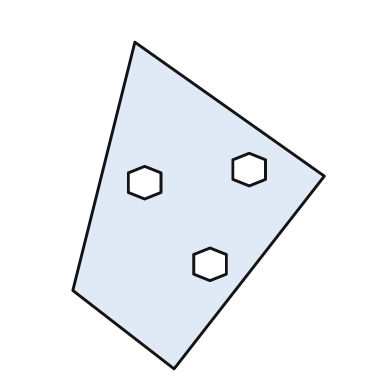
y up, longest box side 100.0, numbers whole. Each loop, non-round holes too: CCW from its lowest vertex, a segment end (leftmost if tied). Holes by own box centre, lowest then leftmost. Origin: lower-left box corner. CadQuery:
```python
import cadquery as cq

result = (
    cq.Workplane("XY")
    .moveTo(31.0, 0.0)
    .lineTo(77.0, 59.0)
    .lineTo(19.0, 100.0)
    .lineTo(0.0, 24.0)
    .close()
    .moveTo(42.0, 27.0)
    .lineTo(47.0, 29.0)
    .lineTo(47.0, 35.0)
    .lineTo(42.0, 37.0)
    .lineTo(37.0, 35.0)
    .lineTo(37.0, 29.0)
    .close()
    .moveTo(22.0, 52.0)
    .lineTo(27.0, 54.0)
    .lineTo(27.0, 60.0)
    .lineTo(22.0, 62.0)
    .lineTo(17.0, 60.0)
    .lineTo(17.0, 54.0)
    .close()
    .moveTo(54.0, 56.0)
    .lineTo(59.0, 58.0)
    .lineTo(59.0, 64.0)
    .lineTo(54.0, 66.0)
    .lineTo(49.0, 64.0)
    .lineTo(49.0, 58.0)
    .close()
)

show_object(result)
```